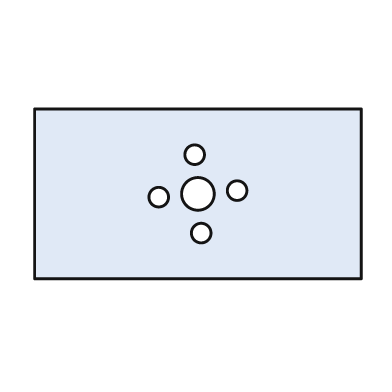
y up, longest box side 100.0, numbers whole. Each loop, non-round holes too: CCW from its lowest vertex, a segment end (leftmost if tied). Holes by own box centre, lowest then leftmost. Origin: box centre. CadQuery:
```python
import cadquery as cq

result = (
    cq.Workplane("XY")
    .moveTo(-50.0, -26.0)
    .lineTo(50.0, -26.0)
    .lineTo(50.0, 26.0)
    .lineTo(-50.0, 26.0)
    .close()
    .moveTo(1.0, -12.0)
    .circle(3.0)
    .moveTo(-12.0, -1.0)
    .circle(3.0)
    .moveTo(0.0, 0.0)
    .circle(5.0)
    .moveTo(12.0, 1.0)
    .circle(3.0)
    .moveTo(-1.0, 12.0)
    .circle(3.0)
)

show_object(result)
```